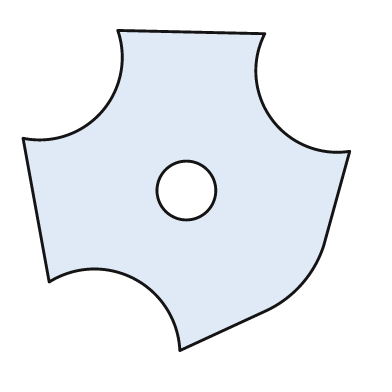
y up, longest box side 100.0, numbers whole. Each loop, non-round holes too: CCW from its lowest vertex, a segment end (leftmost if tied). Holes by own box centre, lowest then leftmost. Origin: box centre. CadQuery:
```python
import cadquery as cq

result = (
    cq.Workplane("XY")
    .moveTo(-2.0, -49.0)
    .lineTo(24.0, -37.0)
    .threePointArc((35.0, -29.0), (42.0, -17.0))
    .lineTo(50.0, 12.0)
    .threePointArc((26.0, 22.0), (24.0, 48.0))
    .lineTo(-21.0, 49.0)
    .threePointArc((-26.0, 24.0), (-50.0, 16.0))
    .lineTo(-42.0, -28.0)
    .threePointArc((-16.0, -27.0), (-2.0, -49.0))
    .close()
    .moveTo(0.0, 0.0)
    .circle(9.0)
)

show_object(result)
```